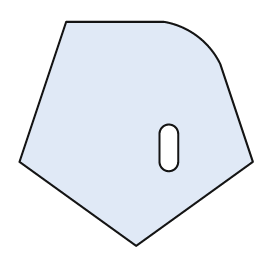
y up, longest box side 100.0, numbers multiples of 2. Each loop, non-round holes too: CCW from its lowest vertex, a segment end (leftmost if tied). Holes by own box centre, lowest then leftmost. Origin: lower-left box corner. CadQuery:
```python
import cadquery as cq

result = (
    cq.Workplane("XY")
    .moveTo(50.0, 0.0)
    .lineTo(100.0, 36.0)
    .lineTo(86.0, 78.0)
    .threePointArc((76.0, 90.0), (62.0, 96.0))
    .lineTo(20.0, 96.0)
    .lineTo(0.0, 36.0)
    .close()
    .moveTo(60.0, 36.0)
    .threePointArc((64.0, 32.0), (68.0, 36.0))
    .lineTo(68.0, 48.0)
    .threePointArc((64.0, 52.0), (60.0, 48.0))
    .close()
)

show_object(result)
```